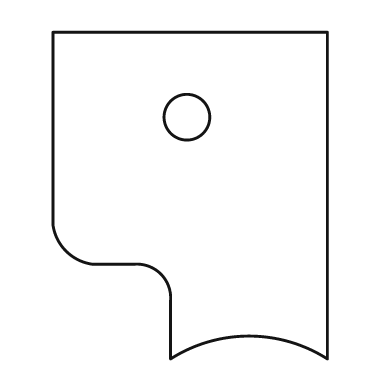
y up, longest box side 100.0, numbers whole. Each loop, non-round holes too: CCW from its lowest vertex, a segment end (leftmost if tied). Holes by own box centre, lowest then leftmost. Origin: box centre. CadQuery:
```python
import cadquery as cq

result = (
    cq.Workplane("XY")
    .moveTo(-6.0, -50.0)
    .threePointArc((18.0, -43.0), (42.0, -50.0))
    .lineTo(42.0, 50.0)
    .lineTo(-42.0, 50.0)
    .lineTo(-42.0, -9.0)
    .threePointArc((-38.0, -17.0), (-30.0, -21.0))
    .lineTo(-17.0, -21.0)
    .threePointArc((-9.0, -24.0), (-6.0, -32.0))
    .close()
    .moveTo(-1.0, 24.0)
    .circle(7.0)
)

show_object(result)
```